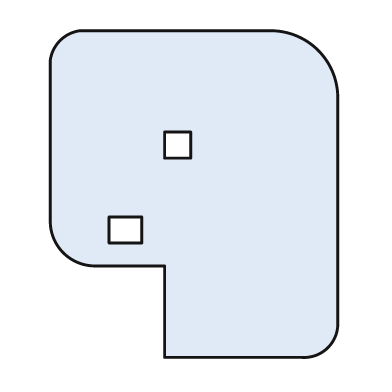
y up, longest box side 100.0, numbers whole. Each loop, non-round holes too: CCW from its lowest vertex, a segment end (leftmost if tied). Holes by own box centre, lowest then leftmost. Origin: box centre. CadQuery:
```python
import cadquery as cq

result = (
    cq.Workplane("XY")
    .moveTo(-9.0, -50.0)
    .lineTo(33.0, -50.0)
    .threePointArc((41.0, -47.0), (44.0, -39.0))
    .lineTo(44.0, 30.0)
    .threePointArc((38.0, 44.0), (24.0, 50.0))
    .lineTo(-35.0, 50.0)
    .threePointArc((-41.0, 47.0), (-44.0, 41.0))
    .lineTo(-44.0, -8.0)
    .threePointArc((-40.0, -18.0), (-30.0, -22.0))
    .lineTo(-9.0, -22.0)
    .close()
    .moveTo(-26.0, -15.0)
    .lineTo(-16.0, -15.0)
    .lineTo(-16.0, -7.0)
    .lineTo(-26.0, -7.0)
    .close()
    .moveTo(-9.0, 11.0)
    .lineTo(-1.0, 11.0)
    .lineTo(-1.0, 19.0)
    .lineTo(-9.0, 19.0)
    .close()
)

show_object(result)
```